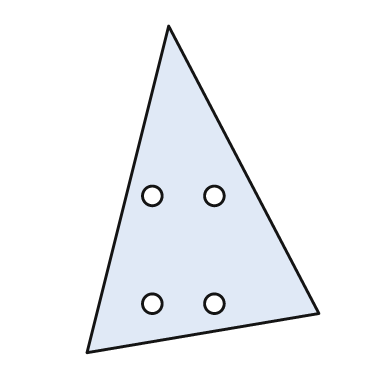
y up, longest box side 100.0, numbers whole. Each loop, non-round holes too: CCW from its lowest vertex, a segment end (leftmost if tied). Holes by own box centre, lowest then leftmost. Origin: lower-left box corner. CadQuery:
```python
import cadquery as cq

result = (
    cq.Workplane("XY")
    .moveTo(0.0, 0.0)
    .lineTo(71.0, 12.0)
    .lineTo(25.0, 100.0)
    .close()
    .moveTo(20.0, 15.0)
    .circle(3.0)
    .moveTo(39.0, 15.0)
    .circle(3.0)
    .moveTo(20.0, 48.0)
    .circle(3.0)
    .moveTo(39.0, 48.0)
    .circle(3.0)
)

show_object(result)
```